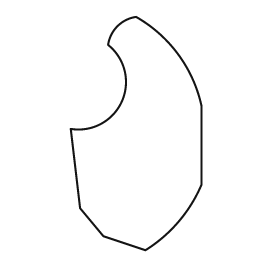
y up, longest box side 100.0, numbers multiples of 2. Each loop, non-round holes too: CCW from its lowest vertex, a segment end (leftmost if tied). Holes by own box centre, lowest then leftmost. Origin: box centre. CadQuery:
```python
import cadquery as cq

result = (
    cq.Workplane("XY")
    .moveTo(4.0, -50.0)
    .threePointArc((18.0, -38.0), (28.0, -22.0))
    .lineTo(28.0, 12.0)
    .threePointArc((18.0, 34.0), (0.0, 50.0))
    .threePointArc((-8.0, 46.0), (-12.0, 38.0))
    .threePointArc((-6.0, 14.0), (-28.0, 2.0))
    .lineTo(-24.0, -32.0)
    .lineTo(-14.0, -44.0)
    .close()
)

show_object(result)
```